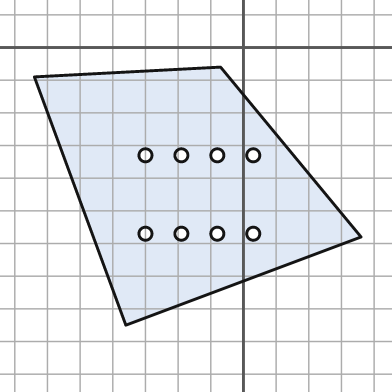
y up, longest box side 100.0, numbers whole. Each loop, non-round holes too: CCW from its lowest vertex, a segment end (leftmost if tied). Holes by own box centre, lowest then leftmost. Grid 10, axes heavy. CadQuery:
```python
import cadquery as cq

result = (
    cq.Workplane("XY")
    .moveTo(-36.0, -85.0)
    .lineTo(36.0, -58.0)
    .lineTo(-7.0, -6.0)
    .lineTo(-64.0, -9.0)
    .close()
    .moveTo(-30.0, -57.0)
    .circle(2.0)
    .moveTo(-19.0, -57.0)
    .circle(2.0)
    .moveTo(-8.0, -57.0)
    .circle(2.0)
    .moveTo(3.0, -57.0)
    .circle(2.0)
    .moveTo(-30.0, -33.0)
    .circle(2.0)
    .moveTo(-19.0, -33.0)
    .circle(2.0)
    .moveTo(-8.0, -33.0)
    .circle(2.0)
    .moveTo(3.0, -33.0)
    .circle(2.0)
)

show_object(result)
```